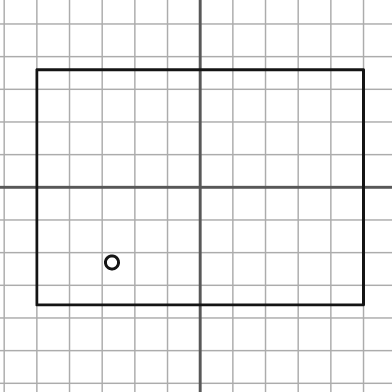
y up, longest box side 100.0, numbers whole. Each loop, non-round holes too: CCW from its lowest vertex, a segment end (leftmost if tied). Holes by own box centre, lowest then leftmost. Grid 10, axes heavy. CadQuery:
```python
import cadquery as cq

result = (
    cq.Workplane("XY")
    .moveTo(-50.0, -36.0)
    .lineTo(50.0, -36.0)
    .lineTo(50.0, 36.0)
    .lineTo(-50.0, 36.0)
    .close()
    .moveTo(-27.0, -23.0)
    .circle(2.0)
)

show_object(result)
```